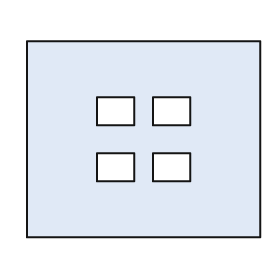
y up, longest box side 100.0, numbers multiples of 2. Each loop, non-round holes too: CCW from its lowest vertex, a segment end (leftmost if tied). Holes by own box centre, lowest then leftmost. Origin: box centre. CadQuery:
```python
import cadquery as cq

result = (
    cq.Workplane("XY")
    .moveTo(-50.0, -42.0)
    .lineTo(50.0, -42.0)
    .lineTo(50.0, 42.0)
    .lineTo(-50.0, 42.0)
    .close()
    .moveTo(-20.0, -18.0)
    .lineTo(-4.0, -18.0)
    .lineTo(-4.0, -6.0)
    .lineTo(-20.0, -6.0)
    .close()
    .moveTo(4.0, -18.0)
    .lineTo(20.0, -18.0)
    .lineTo(20.0, -6.0)
    .lineTo(4.0, -6.0)
    .close()
    .moveTo(-20.0, 6.0)
    .lineTo(-4.0, 6.0)
    .lineTo(-4.0, 18.0)
    .lineTo(-20.0, 18.0)
    .close()
    .moveTo(4.0, 6.0)
    .lineTo(20.0, 6.0)
    .lineTo(20.0, 18.0)
    .lineTo(4.0, 18.0)
    .close()
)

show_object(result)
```